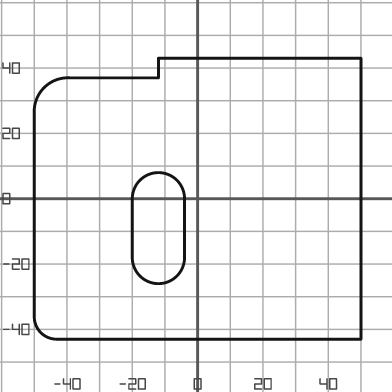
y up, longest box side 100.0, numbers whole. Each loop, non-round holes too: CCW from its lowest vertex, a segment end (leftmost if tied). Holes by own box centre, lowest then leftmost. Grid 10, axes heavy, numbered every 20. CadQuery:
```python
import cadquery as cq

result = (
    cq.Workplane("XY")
    .moveTo(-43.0, -43.0)
    .lineTo(50.0, -43.0)
    .lineTo(50.0, 43.0)
    .lineTo(-12.0, 43.0)
    .lineTo(-12.0, 37.0)
    .lineTo(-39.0, 37.0)
    .threePointArc((-47.0, 34.0), (-50.0, 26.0))
    .lineTo(-50.0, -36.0)
    .threePointArc((-48.0, -41.0), (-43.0, -43.0))
    .close()
    .moveTo(-20.0, -18.0)
    .threePointArc((-12.0, -26.0), (-4.0, -18.0))
    .lineTo(-4.0, 0.0)
    .threePointArc((-12.0, 8.0), (-20.0, 0.0))
    .close()
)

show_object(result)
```